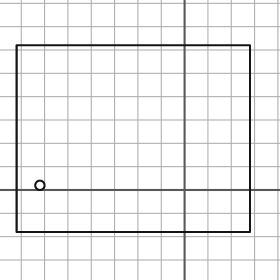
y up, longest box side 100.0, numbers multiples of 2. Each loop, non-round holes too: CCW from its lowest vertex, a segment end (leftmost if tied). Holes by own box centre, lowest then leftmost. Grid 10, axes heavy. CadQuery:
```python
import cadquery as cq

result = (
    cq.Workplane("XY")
    .moveTo(-72.0, -18.0)
    .lineTo(28.0, -18.0)
    .lineTo(28.0, 62.0)
    .lineTo(-72.0, 62.0)
    .close()
    .moveTo(-62.0, 2.0)
    .circle(2.0)
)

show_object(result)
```